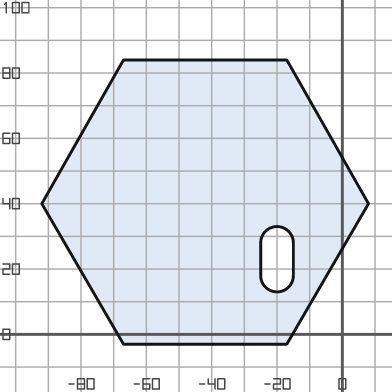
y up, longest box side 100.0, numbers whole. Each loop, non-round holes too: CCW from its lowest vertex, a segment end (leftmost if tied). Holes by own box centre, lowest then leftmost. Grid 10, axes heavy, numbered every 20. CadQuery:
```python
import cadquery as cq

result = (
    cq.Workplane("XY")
    .moveTo(-67.0, -3.0)
    .lineTo(-17.0, -3.0)
    .lineTo(8.0, 40.0)
    .lineTo(-17.0, 84.0)
    .lineTo(-67.0, 84.0)
    .lineTo(-92.0, 40.0)
    .close()
    .moveTo(-25.0, 18.0)
    .threePointArc((-20.0, 13.0), (-15.0, 18.0))
    .lineTo(-15.0, 28.0)
    .threePointArc((-20.0, 33.0), (-25.0, 28.0))
    .close()
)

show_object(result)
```